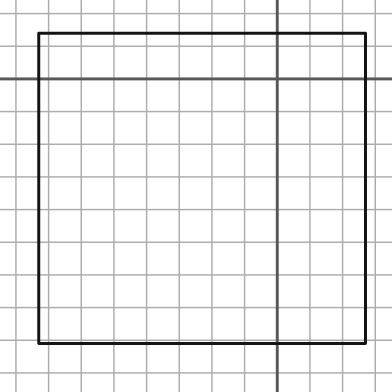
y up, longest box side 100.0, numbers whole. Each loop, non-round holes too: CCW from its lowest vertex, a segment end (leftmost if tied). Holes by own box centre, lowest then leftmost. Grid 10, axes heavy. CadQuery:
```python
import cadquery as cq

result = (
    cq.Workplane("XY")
    .moveTo(-73.0, -81.0)
    .lineTo(27.0, -81.0)
    .lineTo(27.0, 14.0)
    .lineTo(-73.0, 14.0)
    .close()
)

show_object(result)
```